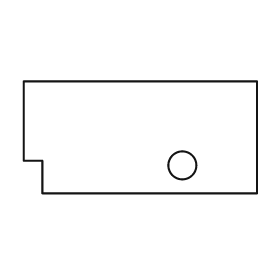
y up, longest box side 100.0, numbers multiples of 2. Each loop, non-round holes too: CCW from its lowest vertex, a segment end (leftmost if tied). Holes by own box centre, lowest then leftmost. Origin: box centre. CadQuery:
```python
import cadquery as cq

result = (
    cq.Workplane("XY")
    .moveTo(-42.0, -24.0)
    .lineTo(50.0, -24.0)
    .lineTo(50.0, 24.0)
    .lineTo(-50.0, 24.0)
    .lineTo(-50.0, -10.0)
    .lineTo(-42.0, -10.0)
    .close()
    .moveTo(18.0, -12.0)
    .circle(6.0)
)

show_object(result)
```